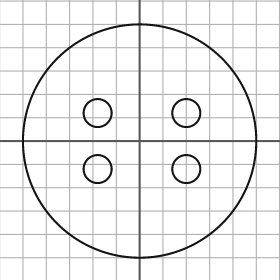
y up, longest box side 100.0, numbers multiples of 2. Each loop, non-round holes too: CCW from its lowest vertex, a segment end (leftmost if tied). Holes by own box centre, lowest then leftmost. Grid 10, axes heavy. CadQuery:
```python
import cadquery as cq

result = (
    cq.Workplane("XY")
    .moveTo(0.0, 0.0)
    .circle(50.0)
    .moveTo(-18.0, -12.0)
    .circle(6.0)
    .moveTo(20.0, -12.0)
    .circle(6.0)
    .moveTo(-18.0, 12.0)
    .circle(6.0)
    .moveTo(20.0, 12.0)
    .circle(6.0)
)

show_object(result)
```